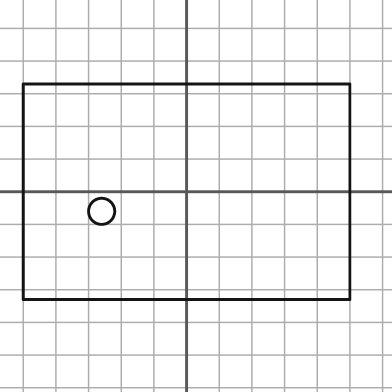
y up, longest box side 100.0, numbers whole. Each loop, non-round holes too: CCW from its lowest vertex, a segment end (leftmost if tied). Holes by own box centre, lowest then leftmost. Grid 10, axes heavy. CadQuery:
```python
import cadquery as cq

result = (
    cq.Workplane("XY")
    .moveTo(-50.0, -33.0)
    .lineTo(50.0, -33.0)
    .lineTo(50.0, 33.0)
    .lineTo(-50.0, 33.0)
    .close()
    .moveTo(-26.0, -6.0)
    .circle(4.0)
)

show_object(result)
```